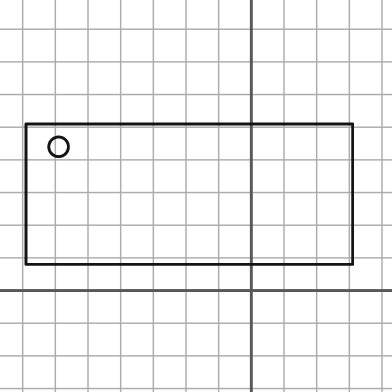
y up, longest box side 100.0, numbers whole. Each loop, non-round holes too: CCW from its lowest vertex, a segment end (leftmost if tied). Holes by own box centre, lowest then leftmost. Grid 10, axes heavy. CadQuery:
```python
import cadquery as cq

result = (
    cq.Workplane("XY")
    .moveTo(-69.0, 8.0)
    .lineTo(31.0, 8.0)
    .lineTo(31.0, 51.0)
    .lineTo(-69.0, 51.0)
    .close()
    .moveTo(-59.0, 44.0)
    .circle(3.0)
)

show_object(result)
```